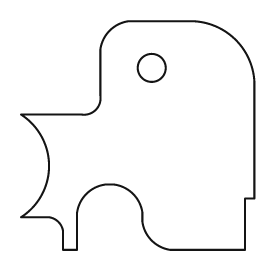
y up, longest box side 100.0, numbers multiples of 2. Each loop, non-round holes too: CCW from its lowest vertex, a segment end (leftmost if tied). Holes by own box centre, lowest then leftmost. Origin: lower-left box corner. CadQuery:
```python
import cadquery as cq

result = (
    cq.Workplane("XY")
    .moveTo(18.0, 0.0)
    .lineTo(24.0, 0.0)
    .lineTo(24.0, 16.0)
    .threePointArc((28.0, 24.0), (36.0, 28.0))
    .lineTo(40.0, 28.0)
    .threePointArc((48.0, 24.0), (52.0, 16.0))
    .lineTo(52.0, 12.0)
    .threePointArc((56.0, 4.0), (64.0, 0.0))
    .lineTo(96.0, 0.0)
    .lineTo(96.0, 22.0)
    .lineTo(100.0, 22.0)
    .lineTo(100.0, 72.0)
    .threePointArc((92.0, 90.0), (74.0, 98.0))
    .lineTo(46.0, 98.0)
    .threePointArc((38.0, 94.0), (34.0, 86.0))
    .lineTo(34.0, 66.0)
    .threePointArc((32.0, 60.0), (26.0, 58.0))
    .lineTo(0.0, 58.0)
    .threePointArc((12.0, 36.0), (0.0, 14.0))
    .lineTo(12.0, 14.0)
    .threePointArc((16.0, 12.0), (18.0, 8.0))
    .close()
    .moveTo(56.0, 78.0)
    .circle(6.0)
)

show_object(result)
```